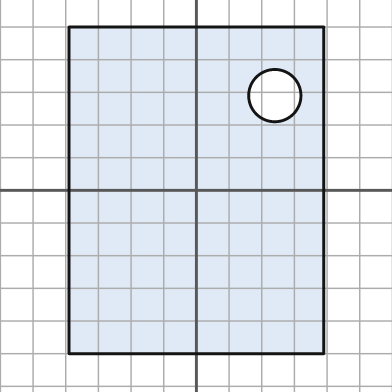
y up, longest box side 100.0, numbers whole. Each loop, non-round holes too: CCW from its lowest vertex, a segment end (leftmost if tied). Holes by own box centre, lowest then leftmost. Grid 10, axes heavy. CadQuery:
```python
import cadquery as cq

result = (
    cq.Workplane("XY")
    .moveTo(-39.0, -50.0)
    .lineTo(39.0, -50.0)
    .lineTo(39.0, 50.0)
    .lineTo(-39.0, 50.0)
    .close()
    .moveTo(24.0, 29.0)
    .circle(8.0)
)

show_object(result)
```